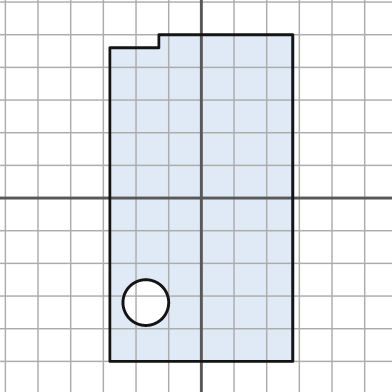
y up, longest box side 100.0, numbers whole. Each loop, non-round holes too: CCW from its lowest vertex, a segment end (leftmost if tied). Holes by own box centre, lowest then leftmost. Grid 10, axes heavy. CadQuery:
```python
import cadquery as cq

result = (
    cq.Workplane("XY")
    .moveTo(-28.0, -50.0)
    .lineTo(28.0, -50.0)
    .lineTo(28.0, 50.0)
    .lineTo(-13.0, 50.0)
    .lineTo(-13.0, 46.0)
    .lineTo(-28.0, 46.0)
    .close()
    .moveTo(-17.0, -32.0)
    .circle(7.0)
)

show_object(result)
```